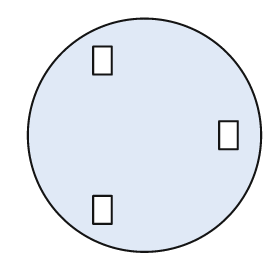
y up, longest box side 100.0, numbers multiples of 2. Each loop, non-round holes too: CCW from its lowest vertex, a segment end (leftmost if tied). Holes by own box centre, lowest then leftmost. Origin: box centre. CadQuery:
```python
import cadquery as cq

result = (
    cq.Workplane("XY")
    .moveTo(0.0, 0.0)
    .circle(50.0)
    .moveTo(-22.0, -38.0)
    .lineTo(-14.0, -38.0)
    .lineTo(-14.0, -26.0)
    .lineTo(-22.0, -26.0)
    .close()
    .moveTo(32.0, -6.0)
    .lineTo(40.0, -6.0)
    .lineTo(40.0, 6.0)
    .lineTo(32.0, 6.0)
    .close()
    .moveTo(-22.0, 26.0)
    .lineTo(-14.0, 26.0)
    .lineTo(-14.0, 38.0)
    .lineTo(-22.0, 38.0)
    .close()
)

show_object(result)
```